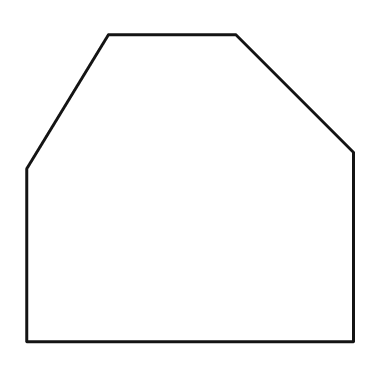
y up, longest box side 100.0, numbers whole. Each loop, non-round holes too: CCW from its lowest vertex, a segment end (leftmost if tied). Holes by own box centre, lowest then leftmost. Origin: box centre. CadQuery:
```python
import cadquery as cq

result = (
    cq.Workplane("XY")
    .moveTo(-50.0, -47.0)
    .lineTo(50.0, -47.0)
    .lineTo(50.0, 11.0)
    .lineTo(14.0, 47.0)
    .lineTo(-25.0, 47.0)
    .lineTo(-50.0, 6.0)
    .close()
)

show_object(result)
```